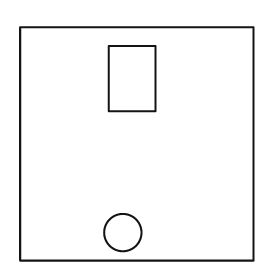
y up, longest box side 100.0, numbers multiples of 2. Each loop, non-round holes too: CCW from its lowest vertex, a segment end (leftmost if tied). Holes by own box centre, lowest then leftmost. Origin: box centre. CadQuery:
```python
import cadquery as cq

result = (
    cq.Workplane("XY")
    .moveTo(-50.0, -50.0)
    .lineTo(50.0, -50.0)
    .lineTo(50.0, 50.0)
    .lineTo(-50.0, 50.0)
    .close()
    .moveTo(-6.0, -38.0)
    .circle(8.0)
    .moveTo(-12.0, 14.0)
    .lineTo(8.0, 14.0)
    .lineTo(8.0, 42.0)
    .lineTo(-12.0, 42.0)
    .close()
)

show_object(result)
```